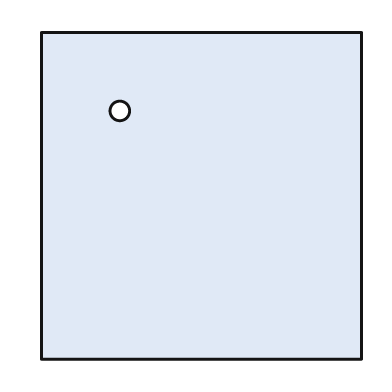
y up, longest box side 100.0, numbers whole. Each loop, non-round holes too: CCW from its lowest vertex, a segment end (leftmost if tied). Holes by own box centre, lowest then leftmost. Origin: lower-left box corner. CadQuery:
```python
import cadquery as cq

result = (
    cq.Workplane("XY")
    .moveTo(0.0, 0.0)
    .lineTo(98.0, 0.0)
    .lineTo(98.0, 100.0)
    .lineTo(0.0, 100.0)
    .close()
    .moveTo(24.0, 76.0)
    .circle(3.0)
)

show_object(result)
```